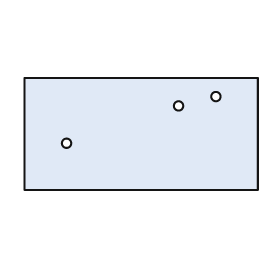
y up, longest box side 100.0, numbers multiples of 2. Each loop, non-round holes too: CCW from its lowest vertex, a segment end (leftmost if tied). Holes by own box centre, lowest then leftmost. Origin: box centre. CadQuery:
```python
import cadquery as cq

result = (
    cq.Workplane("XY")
    .moveTo(-50.0, -24.0)
    .lineTo(50.0, -24.0)
    .lineTo(50.0, 24.0)
    .lineTo(-50.0, 24.0)
    .close()
    .moveTo(-32.0, -4.0)
    .circle(2.0)
    .moveTo(16.0, 12.0)
    .circle(2.0)
    .moveTo(32.0, 16.0)
    .circle(2.0)
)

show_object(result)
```